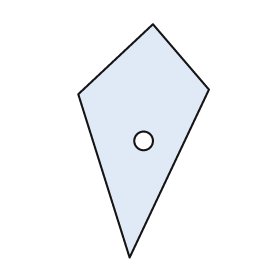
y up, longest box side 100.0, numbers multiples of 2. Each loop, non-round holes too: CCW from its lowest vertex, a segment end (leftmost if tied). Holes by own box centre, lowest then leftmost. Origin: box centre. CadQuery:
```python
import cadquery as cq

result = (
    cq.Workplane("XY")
    .moveTo(-6.0, -50.0)
    .lineTo(28.0, 22.0)
    .lineTo(4.0, 50.0)
    .lineTo(-28.0, 20.0)
    .close()
    .moveTo(0.0, 0.0)
    .circle(4.0)
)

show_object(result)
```